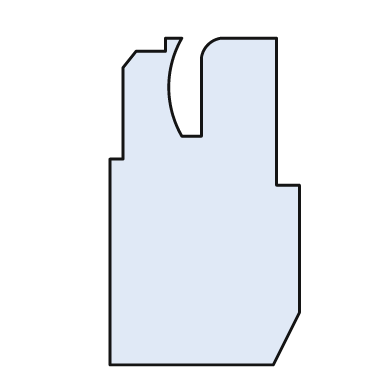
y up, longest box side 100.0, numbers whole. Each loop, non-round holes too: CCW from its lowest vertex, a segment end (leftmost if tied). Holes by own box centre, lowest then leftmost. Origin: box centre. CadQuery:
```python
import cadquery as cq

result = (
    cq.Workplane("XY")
    .moveTo(-29.0, -50.0)
    .lineTo(21.0, -50.0)
    .lineTo(29.0, -34.0)
    .lineTo(29.0, 5.0)
    .lineTo(22.0, 5.0)
    .lineTo(22.0, 50.0)
    .lineTo(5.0, 50.0)
    .threePointArc((1.0, 48.0), (-1.0, 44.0))
    .lineTo(-1.0, 20.0)
    .lineTo(-7.0, 20.0)
    .threePointArc((-11.0, 35.0), (-7.0, 50.0))
    .lineTo(-12.0, 50.0)
    .lineTo(-12.0, 46.0)
    .lineTo(-21.0, 46.0)
    .lineTo(-25.0, 41.0)
    .lineTo(-25.0, 13.0)
    .lineTo(-29.0, 13.0)
    .close()
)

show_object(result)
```